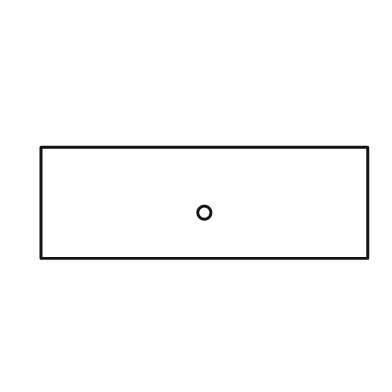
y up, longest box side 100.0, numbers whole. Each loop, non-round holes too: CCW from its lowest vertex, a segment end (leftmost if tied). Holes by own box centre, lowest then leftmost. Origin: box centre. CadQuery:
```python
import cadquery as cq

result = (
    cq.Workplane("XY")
    .moveTo(-50.0, -17.0)
    .lineTo(50.0, -17.0)
    .lineTo(50.0, 17.0)
    .lineTo(-50.0, 17.0)
    .close()
    .moveTo(0.0, -3.0)
    .circle(2.0)
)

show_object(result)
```